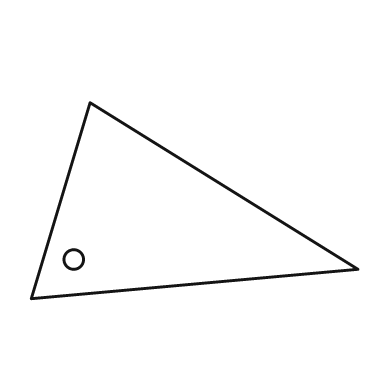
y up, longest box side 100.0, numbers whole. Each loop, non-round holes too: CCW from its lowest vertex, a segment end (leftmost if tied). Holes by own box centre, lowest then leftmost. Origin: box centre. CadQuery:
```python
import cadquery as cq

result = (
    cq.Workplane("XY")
    .moveTo(-50.0, -30.0)
    .lineTo(50.0, -21.0)
    .lineTo(-32.0, 30.0)
    .close()
    .moveTo(-37.0, -18.0)
    .circle(3.0)
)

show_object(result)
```